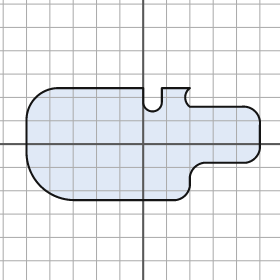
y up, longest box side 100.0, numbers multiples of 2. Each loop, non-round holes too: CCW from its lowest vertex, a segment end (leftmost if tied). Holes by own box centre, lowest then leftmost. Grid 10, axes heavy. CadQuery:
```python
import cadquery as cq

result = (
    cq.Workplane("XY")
    .moveTo(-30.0, -24.0)
    .lineTo(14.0, -24.0)
    .threePointArc((18.0, -22.0), (20.0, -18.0))
    .lineTo(20.0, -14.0)
    .threePointArc((22.0, -10.0), (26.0, -8.0))
    .lineTo(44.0, -8.0)
    .threePointArc((48.0, -6.0), (50.0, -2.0))
    .lineTo(50.0, 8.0)
    .threePointArc((48.0, 14.0), (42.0, 16.0))
    .lineTo(20.0, 16.0)
    .threePointArc((18.0, 20.0), (20.0, 24.0))
    .lineTo(8.0, 24.0)
    .lineTo(8.0, 18.0)
    .threePointArc((4.0, 14.0), (0.0, 18.0))
    .lineTo(0.0, 24.0)
    .lineTo(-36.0, 24.0)
    .threePointArc((-46.0, 20.0), (-50.0, 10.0))
    .lineTo(-50.0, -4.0)
    .threePointArc((-44.0, -18.0), (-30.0, -24.0))
    .close()
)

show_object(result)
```